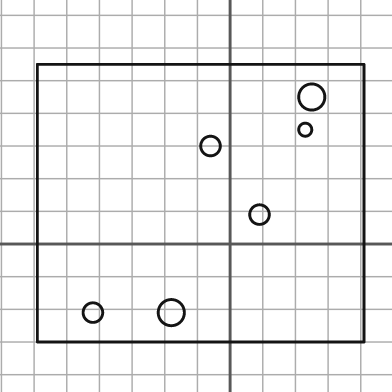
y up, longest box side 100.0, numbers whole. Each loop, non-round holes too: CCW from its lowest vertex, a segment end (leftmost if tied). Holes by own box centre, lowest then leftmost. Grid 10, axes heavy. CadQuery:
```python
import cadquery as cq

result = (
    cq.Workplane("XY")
    .moveTo(-59.0, -30.0)
    .lineTo(41.0, -30.0)
    .lineTo(41.0, 55.0)
    .lineTo(-59.0, 55.0)
    .close()
    .moveTo(-42.0, -21.0)
    .circle(3.0)
    .moveTo(-18.0, -21.0)
    .circle(4.0)
    .moveTo(9.0, 9.0)
    .circle(3.0)
    .moveTo(-6.0, 30.0)
    .circle(3.0)
    .moveTo(23.0, 35.0)
    .circle(2.0)
    .moveTo(25.0, 45.0)
    .circle(4.0)
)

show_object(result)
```